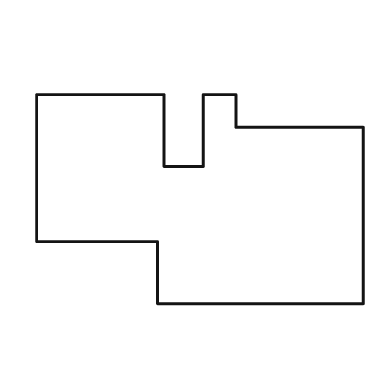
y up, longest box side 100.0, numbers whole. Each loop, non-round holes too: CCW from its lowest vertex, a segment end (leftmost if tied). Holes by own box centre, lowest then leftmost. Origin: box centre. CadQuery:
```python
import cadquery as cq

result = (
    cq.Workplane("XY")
    .moveTo(-13.0, -32.0)
    .lineTo(50.0, -32.0)
    .lineTo(50.0, 22.0)
    .lineTo(11.0, 22.0)
    .lineTo(11.0, 32.0)
    .lineTo(1.0, 32.0)
    .lineTo(1.0, 10.0)
    .lineTo(-11.0, 10.0)
    .lineTo(-11.0, 32.0)
    .lineTo(-50.0, 32.0)
    .lineTo(-50.0, -13.0)
    .lineTo(-13.0, -13.0)
    .close()
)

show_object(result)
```